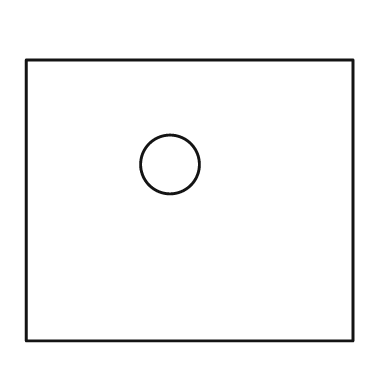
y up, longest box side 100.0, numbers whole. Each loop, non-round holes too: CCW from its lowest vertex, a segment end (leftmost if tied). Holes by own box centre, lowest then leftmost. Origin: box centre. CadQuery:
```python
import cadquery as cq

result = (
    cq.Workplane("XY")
    .moveTo(-50.0, -43.0)
    .lineTo(50.0, -43.0)
    .lineTo(50.0, 43.0)
    .lineTo(-50.0, 43.0)
    .close()
    .moveTo(-6.0, 11.0)
    .circle(9.0)
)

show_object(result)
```